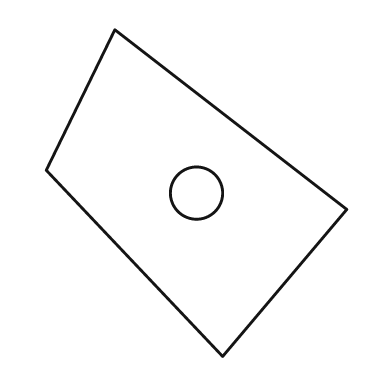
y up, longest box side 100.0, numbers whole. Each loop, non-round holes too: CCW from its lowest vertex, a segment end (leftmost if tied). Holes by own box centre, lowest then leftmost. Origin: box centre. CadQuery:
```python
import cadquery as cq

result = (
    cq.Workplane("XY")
    .moveTo(8.0, -50.0)
    .lineTo(46.0, -5.0)
    .lineTo(-25.0, 50.0)
    .lineTo(-46.0, 7.0)
    .close()
    .moveTo(0.0, 0.0)
    .circle(8.0)
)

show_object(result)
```